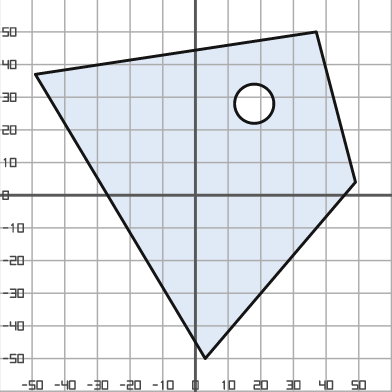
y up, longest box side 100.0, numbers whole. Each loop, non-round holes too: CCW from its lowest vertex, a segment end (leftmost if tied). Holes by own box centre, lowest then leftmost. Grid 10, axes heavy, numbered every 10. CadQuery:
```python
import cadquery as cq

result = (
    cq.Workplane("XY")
    .moveTo(3.0, -50.0)
    .lineTo(49.0, 4.0)
    .lineTo(37.0, 50.0)
    .lineTo(-49.0, 37.0)
    .close()
    .moveTo(18.0, 28.0)
    .circle(6.0)
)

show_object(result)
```